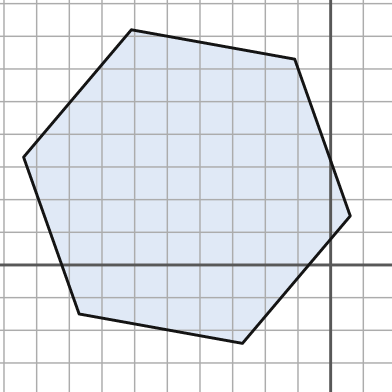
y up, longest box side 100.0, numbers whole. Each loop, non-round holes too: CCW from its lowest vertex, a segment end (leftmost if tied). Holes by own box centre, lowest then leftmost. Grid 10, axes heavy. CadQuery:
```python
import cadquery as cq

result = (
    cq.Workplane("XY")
    .moveTo(-27.0, -24.0)
    .lineTo(6.0, 15.0)
    .lineTo(-11.0, 63.0)
    .lineTo(-61.0, 72.0)
    .lineTo(-94.0, 33.0)
    .lineTo(-77.0, -15.0)
    .close()
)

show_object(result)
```